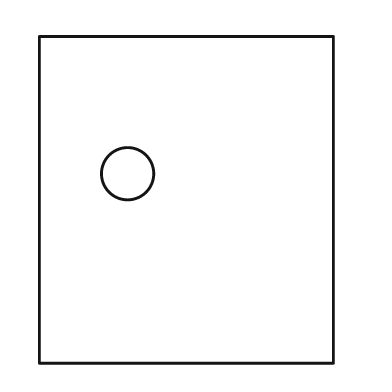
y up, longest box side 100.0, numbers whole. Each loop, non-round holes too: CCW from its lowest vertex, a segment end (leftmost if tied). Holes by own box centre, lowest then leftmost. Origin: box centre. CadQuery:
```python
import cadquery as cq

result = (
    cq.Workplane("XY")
    .moveTo(-45.0, -50.0)
    .lineTo(45.0, -50.0)
    .lineTo(45.0, 50.0)
    .lineTo(-45.0, 50.0)
    .close()
    .moveTo(-18.0, 8.0)
    .circle(8.0)
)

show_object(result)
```